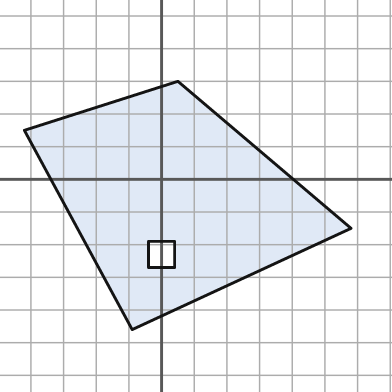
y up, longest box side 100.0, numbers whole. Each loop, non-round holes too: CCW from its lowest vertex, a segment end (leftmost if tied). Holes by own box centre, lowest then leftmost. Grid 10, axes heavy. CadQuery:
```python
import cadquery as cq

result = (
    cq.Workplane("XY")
    .moveTo(-9.0, -46.0)
    .lineTo(58.0, -15.0)
    .lineTo(5.0, 30.0)
    .lineTo(-42.0, 15.0)
    .close()
    .moveTo(-4.0, -27.0)
    .lineTo(4.0, -27.0)
    .lineTo(4.0, -19.0)
    .lineTo(-4.0, -19.0)
    .close()
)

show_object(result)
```